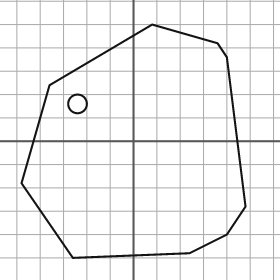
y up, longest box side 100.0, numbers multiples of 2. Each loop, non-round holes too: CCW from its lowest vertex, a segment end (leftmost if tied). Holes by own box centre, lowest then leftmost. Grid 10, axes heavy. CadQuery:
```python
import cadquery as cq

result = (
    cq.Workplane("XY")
    .moveTo(-26.0, -50.0)
    .lineTo(24.0, -48.0)
    .lineTo(40.0, -40.0)
    .lineTo(48.0, -28.0)
    .lineTo(40.0, 36.0)
    .lineTo(36.0, 42.0)
    .lineTo(8.0, 50.0)
    .lineTo(-36.0, 24.0)
    .lineTo(-48.0, -18.0)
    .close()
    .moveTo(-24.0, 16.0)
    .circle(4.0)
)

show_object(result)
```